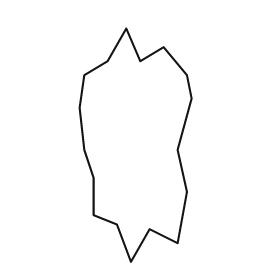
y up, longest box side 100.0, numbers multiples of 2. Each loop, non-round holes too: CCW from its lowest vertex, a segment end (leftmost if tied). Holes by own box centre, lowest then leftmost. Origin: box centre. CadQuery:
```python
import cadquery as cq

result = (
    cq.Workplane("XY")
    .moveTo(-2.0, -50.0)
    .lineTo(6.0, -36.0)
    .lineTo(18.0, -42.0)
    .lineTo(22.0, -20.0)
    .lineTo(18.0, -2.0)
    .lineTo(24.0, 20.0)
    .lineTo(22.0, 30.0)
    .lineTo(12.0, 42.0)
    .lineTo(2.0, 36.0)
    .lineTo(-4.0, 50.0)
    .lineTo(-12.0, 36.0)
    .lineTo(-22.0, 30.0)
    .lineTo(-24.0, 16.0)
    .lineTo(-22.0, -2.0)
    .lineTo(-18.0, -14.0)
    .lineTo(-18.0, -30.0)
    .lineTo(-8.0, -34.0)
    .close()
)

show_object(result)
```